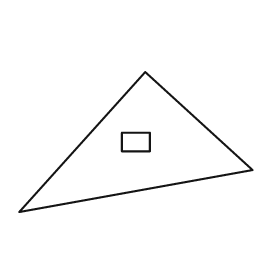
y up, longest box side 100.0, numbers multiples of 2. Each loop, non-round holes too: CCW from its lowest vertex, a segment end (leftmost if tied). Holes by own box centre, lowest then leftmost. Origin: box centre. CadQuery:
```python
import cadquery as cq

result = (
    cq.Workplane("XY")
    .moveTo(-50.0, -30.0)
    .lineTo(50.0, -12.0)
    .lineTo(4.0, 30.0)
    .close()
    .moveTo(-6.0, -4.0)
    .lineTo(6.0, -4.0)
    .lineTo(6.0, 4.0)
    .lineTo(-6.0, 4.0)
    .close()
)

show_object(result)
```